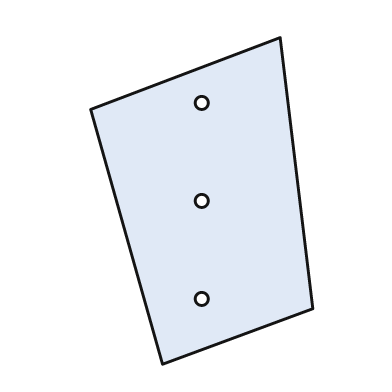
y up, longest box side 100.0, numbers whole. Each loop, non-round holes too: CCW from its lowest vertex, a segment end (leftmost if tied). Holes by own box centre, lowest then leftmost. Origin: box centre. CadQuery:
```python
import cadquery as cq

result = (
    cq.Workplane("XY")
    .moveTo(-12.0, -50.0)
    .lineTo(34.0, -33.0)
    .lineTo(24.0, 50.0)
    .lineTo(-34.0, 28.0)
    .close()
    .moveTo(0.0, -30.0)
    .circle(2.0)
    .moveTo(0.0, 0.0)
    .circle(2.0)
    .moveTo(0.0, 30.0)
    .circle(2.0)
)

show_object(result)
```